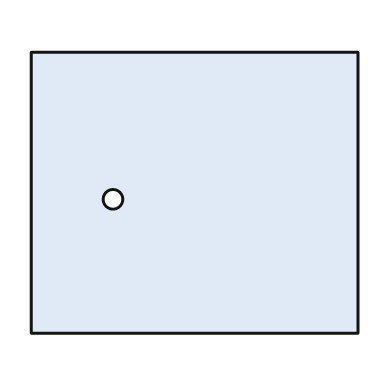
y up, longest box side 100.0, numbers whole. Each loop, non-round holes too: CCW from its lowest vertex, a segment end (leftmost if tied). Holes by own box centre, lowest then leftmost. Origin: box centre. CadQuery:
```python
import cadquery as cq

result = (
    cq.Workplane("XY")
    .moveTo(-50.0, -43.0)
    .lineTo(50.0, -43.0)
    .lineTo(50.0, 43.0)
    .lineTo(-50.0, 43.0)
    .close()
    .moveTo(-25.0, -2.0)
    .circle(3.0)
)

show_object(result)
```